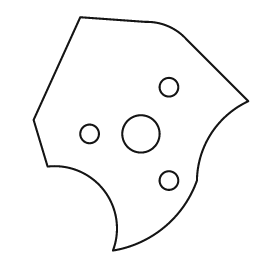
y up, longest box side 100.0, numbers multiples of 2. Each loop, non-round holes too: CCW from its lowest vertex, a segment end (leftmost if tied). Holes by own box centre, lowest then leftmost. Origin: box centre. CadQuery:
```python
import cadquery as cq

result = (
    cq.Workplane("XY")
    .moveTo(-12.0, -50.0)
    .threePointArc((10.0, -40.0), (24.0, -20.0))
    .threePointArc((30.0, 0.0), (46.0, 14.0))
    .lineTo(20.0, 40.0)
    .threePointArc((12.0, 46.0), (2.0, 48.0))
    .lineTo(-26.0, 50.0)
    .lineTo(-46.0, 6.0)
    .lineTo(-40.0, -14.0)
    .threePointArc((-16.0, -24.0), (-12.0, -50.0))
    .close()
    .moveTo(12.0, -20.0)
    .circle(4.0)
    .moveTo(-22.0, 0.0)
    .circle(4.0)
    .moveTo(0.0, 0.0)
    .circle(8.0)
    .moveTo(12.0, 20.0)
    .circle(4.0)
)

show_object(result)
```